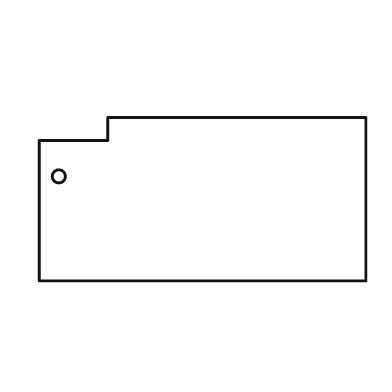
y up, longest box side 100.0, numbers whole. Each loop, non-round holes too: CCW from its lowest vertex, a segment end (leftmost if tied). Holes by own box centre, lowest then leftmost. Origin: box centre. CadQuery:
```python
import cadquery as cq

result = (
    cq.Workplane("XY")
    .moveTo(-50.0, -25.0)
    .lineTo(50.0, -25.0)
    .lineTo(50.0, 25.0)
    .lineTo(-29.0, 25.0)
    .lineTo(-29.0, 18.0)
    .lineTo(-50.0, 18.0)
    .close()
    .moveTo(-44.0, 7.0)
    .circle(2.0)
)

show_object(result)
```